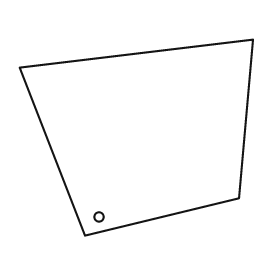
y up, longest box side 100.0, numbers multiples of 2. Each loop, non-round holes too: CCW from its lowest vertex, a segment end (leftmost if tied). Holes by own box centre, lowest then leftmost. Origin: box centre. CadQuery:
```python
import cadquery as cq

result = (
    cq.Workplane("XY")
    .moveTo(-22.0, -42.0)
    .lineTo(44.0, -26.0)
    .lineTo(50.0, 42.0)
    .lineTo(-50.0, 30.0)
    .close()
    .moveTo(-16.0, -34.0)
    .circle(2.0)
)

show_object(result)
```